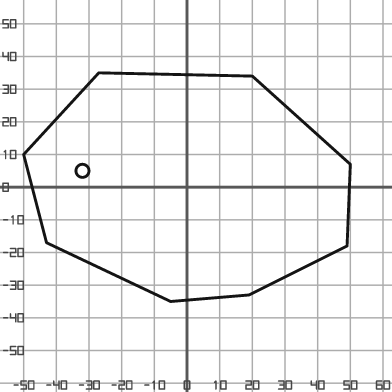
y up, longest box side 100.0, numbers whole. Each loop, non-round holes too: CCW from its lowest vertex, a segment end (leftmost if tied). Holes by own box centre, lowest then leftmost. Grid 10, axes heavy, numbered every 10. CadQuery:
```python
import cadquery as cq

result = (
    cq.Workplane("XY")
    .moveTo(-5.0, -35.0)
    .lineTo(19.0, -33.0)
    .lineTo(49.0, -18.0)
    .lineTo(50.0, 7.0)
    .lineTo(20.0, 34.0)
    .lineTo(-27.0, 35.0)
    .lineTo(-50.0, 10.0)
    .lineTo(-43.0, -17.0)
    .close()
    .moveTo(-32.0, 5.0)
    .circle(2.0)
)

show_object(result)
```